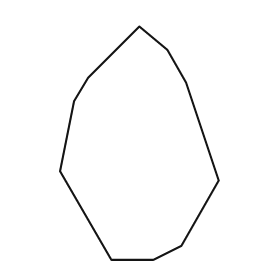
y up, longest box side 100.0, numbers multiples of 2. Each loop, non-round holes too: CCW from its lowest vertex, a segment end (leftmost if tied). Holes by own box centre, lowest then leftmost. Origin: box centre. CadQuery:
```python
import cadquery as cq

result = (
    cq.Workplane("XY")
    .moveTo(-12.0, -50.0)
    .lineTo(6.0, -50.0)
    .lineTo(18.0, -44.0)
    .lineTo(34.0, -16.0)
    .lineTo(20.0, 26.0)
    .lineTo(12.0, 40.0)
    .lineTo(0.0, 50.0)
    .lineTo(-22.0, 28.0)
    .lineTo(-28.0, 18.0)
    .lineTo(-34.0, -12.0)
    .close()
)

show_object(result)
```